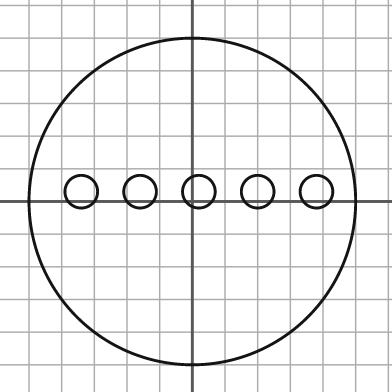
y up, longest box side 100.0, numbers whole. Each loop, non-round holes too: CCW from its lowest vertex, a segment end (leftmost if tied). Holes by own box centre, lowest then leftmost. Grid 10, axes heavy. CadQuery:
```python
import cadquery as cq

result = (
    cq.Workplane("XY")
    .moveTo(0.0, 0.0)
    .circle(50.0)
    .moveTo(-34.0, 3.0)
    .circle(5.0)
    .moveTo(-16.0, 3.0)
    .circle(5.0)
    .moveTo(2.0, 3.0)
    .circle(5.0)
    .moveTo(20.0, 3.0)
    .circle(5.0)
    .moveTo(38.0, 3.0)
    .circle(5.0)
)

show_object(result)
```